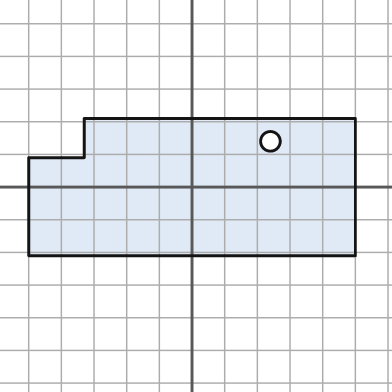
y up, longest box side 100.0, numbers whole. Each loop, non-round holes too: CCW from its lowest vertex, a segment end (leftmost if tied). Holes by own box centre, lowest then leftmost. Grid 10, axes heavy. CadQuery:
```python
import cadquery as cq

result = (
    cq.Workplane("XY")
    .moveTo(-50.0, -21.0)
    .lineTo(50.0, -21.0)
    .lineTo(50.0, 21.0)
    .lineTo(-33.0, 21.0)
    .lineTo(-33.0, 9.0)
    .lineTo(-50.0, 9.0)
    .close()
    .moveTo(24.0, 14.0)
    .circle(3.0)
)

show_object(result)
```